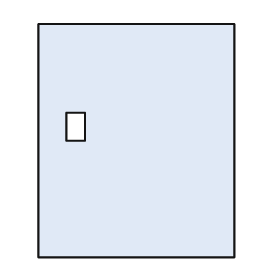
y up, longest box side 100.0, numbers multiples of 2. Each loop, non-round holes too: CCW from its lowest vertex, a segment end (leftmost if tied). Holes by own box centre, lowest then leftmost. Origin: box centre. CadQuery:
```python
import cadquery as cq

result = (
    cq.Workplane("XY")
    .moveTo(-42.0, -50.0)
    .lineTo(42.0, -50.0)
    .lineTo(42.0, 50.0)
    .lineTo(-42.0, 50.0)
    .close()
    .moveTo(-30.0, 0.0)
    .lineTo(-22.0, 0.0)
    .lineTo(-22.0, 12.0)
    .lineTo(-30.0, 12.0)
    .close()
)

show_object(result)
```